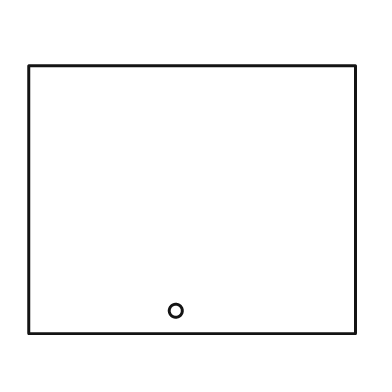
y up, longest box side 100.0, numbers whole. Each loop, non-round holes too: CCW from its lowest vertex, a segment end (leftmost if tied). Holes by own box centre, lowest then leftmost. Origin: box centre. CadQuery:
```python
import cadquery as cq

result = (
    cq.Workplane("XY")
    .moveTo(-50.0, -41.0)
    .lineTo(50.0, -41.0)
    .lineTo(50.0, 41.0)
    .lineTo(-50.0, 41.0)
    .close()
    .moveTo(-5.0, -34.0)
    .circle(2.0)
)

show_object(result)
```